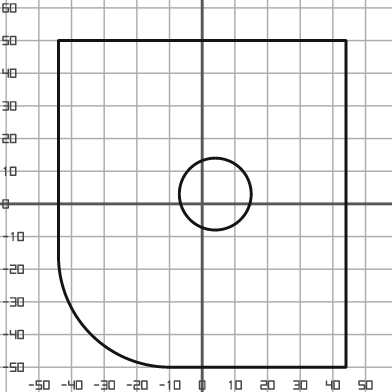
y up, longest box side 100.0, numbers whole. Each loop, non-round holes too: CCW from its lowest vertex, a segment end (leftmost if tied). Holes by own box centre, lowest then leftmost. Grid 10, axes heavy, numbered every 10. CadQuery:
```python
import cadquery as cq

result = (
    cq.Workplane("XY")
    .moveTo(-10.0, -50.0)
    .lineTo(44.0, -50.0)
    .lineTo(44.0, 50.0)
    .lineTo(-44.0, 50.0)
    .lineTo(-44.0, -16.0)
    .threePointArc((-34.0, -40.0), (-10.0, -50.0))
    .close()
    .moveTo(4.0, 3.0)
    .circle(11.0)
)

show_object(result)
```